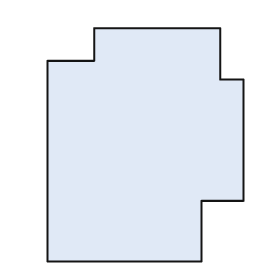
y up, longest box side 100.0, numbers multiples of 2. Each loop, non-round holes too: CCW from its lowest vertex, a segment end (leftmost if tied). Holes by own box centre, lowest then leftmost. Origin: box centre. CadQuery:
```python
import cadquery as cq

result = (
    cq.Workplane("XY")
    .moveTo(-42.0, -50.0)
    .lineTo(24.0, -50.0)
    .lineTo(24.0, -24.0)
    .lineTo(42.0, -24.0)
    .lineTo(42.0, 28.0)
    .lineTo(32.0, 28.0)
    .lineTo(32.0, 50.0)
    .lineTo(-22.0, 50.0)
    .lineTo(-22.0, 36.0)
    .lineTo(-42.0, 36.0)
    .close()
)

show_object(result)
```